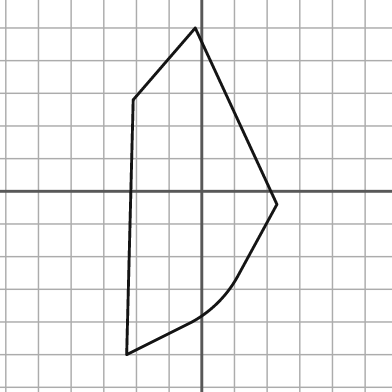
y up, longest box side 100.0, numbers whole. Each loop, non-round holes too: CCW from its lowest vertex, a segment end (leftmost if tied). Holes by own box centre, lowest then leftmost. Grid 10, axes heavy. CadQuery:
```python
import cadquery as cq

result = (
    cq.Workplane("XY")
    .moveTo(-23.0, -50.0)
    .lineTo(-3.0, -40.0)
    .threePointArc((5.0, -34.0), (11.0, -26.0))
    .lineTo(23.0, -4.0)
    .lineTo(-2.0, 50.0)
    .lineTo(-21.0, 28.0)
    .close()
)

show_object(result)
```